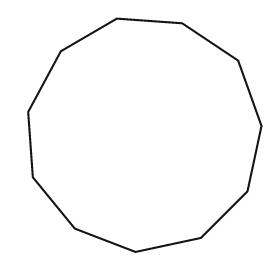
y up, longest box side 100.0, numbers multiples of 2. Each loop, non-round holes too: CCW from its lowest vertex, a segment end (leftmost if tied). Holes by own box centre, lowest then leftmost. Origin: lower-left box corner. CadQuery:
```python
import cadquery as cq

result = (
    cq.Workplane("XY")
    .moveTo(46.0, 0.0)
    .lineTo(74.0, 6.0)
    .lineTo(94.0, 26.0)
    .lineTo(100.0, 54.0)
    .lineTo(90.0, 82.0)
    .lineTo(66.0, 98.0)
    .lineTo(38.0, 100.0)
    .lineTo(14.0, 86.0)
    .lineTo(0.0, 60.0)
    .lineTo(2.0, 32.0)
    .lineTo(20.0, 10.0)
    .close()
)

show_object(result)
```